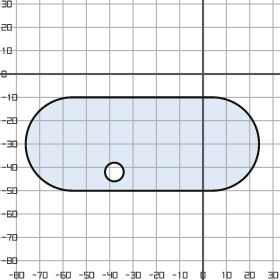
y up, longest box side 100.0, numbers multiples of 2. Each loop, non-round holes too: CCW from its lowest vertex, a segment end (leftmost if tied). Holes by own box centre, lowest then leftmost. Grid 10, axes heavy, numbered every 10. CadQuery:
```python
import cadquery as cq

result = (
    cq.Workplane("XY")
    .moveTo(-56.0, -50.0)
    .lineTo(4.0, -50.0)
    .threePointArc((24.0, -30.0), (4.0, -10.0))
    .lineTo(-56.0, -10.0)
    .threePointArc((-76.0, -30.0), (-56.0, -50.0))
    .close()
    .moveTo(-38.0, -42.0)
    .circle(4.0)
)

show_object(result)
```